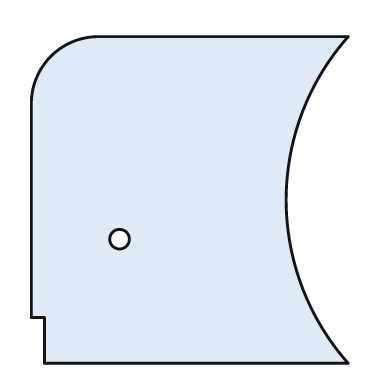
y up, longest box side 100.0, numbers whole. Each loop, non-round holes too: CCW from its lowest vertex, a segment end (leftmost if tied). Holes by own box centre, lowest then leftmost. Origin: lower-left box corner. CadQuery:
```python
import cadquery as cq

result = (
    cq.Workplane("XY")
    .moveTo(4.0, 0.0)
    .lineTo(97.0, 0.0)
    .threePointArc((78.0, 50.0), (97.0, 100.0))
    .lineTo(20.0, 100.0)
    .threePointArc((6.0, 94.0), (0.0, 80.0))
    .lineTo(0.0, 14.0)
    .lineTo(4.0, 14.0)
    .close()
    .moveTo(27.0, 38.0)
    .circle(3.0)
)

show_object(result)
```